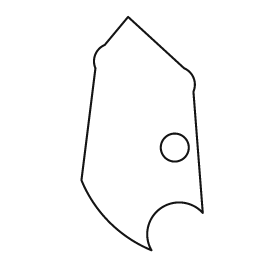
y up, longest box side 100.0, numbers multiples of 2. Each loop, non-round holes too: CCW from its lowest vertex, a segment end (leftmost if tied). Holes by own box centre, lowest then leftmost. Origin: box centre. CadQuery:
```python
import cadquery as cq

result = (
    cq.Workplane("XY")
    .moveTo(4.0, -50.0)
    .threePointArc((8.0, -32.0), (26.0, -34.0))
    .lineTo(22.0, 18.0)
    .threePointArc((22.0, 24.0), (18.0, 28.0))
    .lineTo(-6.0, 50.0)
    .lineTo(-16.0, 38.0)
    .threePointArc((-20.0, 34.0), (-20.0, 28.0))
    .lineTo(-26.0, -20.0)
    .threePointArc((-14.0, -38.0), (4.0, -50.0))
    .close()
    .moveTo(14.0, -6.0)
    .circle(6.0)
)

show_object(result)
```